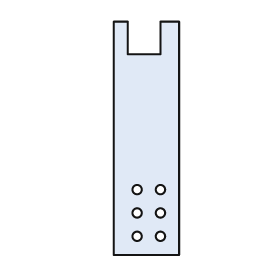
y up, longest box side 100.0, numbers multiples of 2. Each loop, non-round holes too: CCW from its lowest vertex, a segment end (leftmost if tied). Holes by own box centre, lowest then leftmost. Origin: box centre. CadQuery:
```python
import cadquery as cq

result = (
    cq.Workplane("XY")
    .moveTo(-14.0, -50.0)
    .lineTo(14.0, -50.0)
    .lineTo(14.0, 50.0)
    .lineTo(6.0, 50.0)
    .lineTo(6.0, 36.0)
    .lineTo(-8.0, 36.0)
    .lineTo(-8.0, 50.0)
    .lineTo(-14.0, 50.0)
    .close()
    .moveTo(-4.0, -42.0)
    .circle(2.0)
    .moveTo(6.0, -42.0)
    .circle(2.0)
    .moveTo(-4.0, -32.0)
    .circle(2.0)
    .moveTo(6.0, -32.0)
    .circle(2.0)
    .moveTo(-4.0, -22.0)
    .circle(2.0)
    .moveTo(6.0, -22.0)
    .circle(2.0)
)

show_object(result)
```